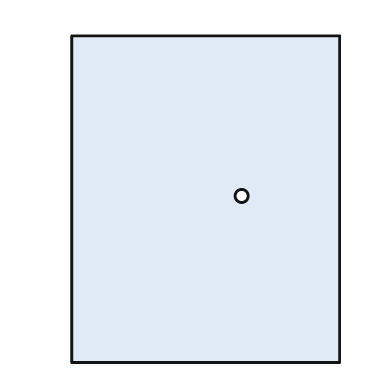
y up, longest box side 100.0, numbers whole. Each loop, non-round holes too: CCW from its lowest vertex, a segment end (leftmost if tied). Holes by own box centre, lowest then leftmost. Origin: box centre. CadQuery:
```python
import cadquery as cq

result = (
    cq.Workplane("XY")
    .moveTo(-41.0, -50.0)
    .lineTo(41.0, -50.0)
    .lineTo(41.0, 50.0)
    .lineTo(-41.0, 50.0)
    .close()
    .moveTo(11.0, 1.0)
    .circle(2.0)
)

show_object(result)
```